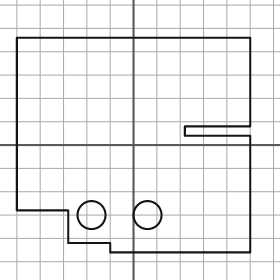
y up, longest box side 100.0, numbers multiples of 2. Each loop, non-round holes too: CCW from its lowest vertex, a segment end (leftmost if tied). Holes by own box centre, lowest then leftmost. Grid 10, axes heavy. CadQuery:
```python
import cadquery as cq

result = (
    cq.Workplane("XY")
    .moveTo(-10.0, -46.0)
    .lineTo(50.0, -46.0)
    .lineTo(50.0, 4.0)
    .lineTo(22.0, 4.0)
    .lineTo(22.0, 8.0)
    .lineTo(50.0, 8.0)
    .lineTo(50.0, 46.0)
    .lineTo(-50.0, 46.0)
    .lineTo(-50.0, -28.0)
    .lineTo(-28.0, -28.0)
    .lineTo(-28.0, -42.0)
    .lineTo(-10.0, -42.0)
    .close()
    .moveTo(-18.0, -30.0)
    .circle(6.0)
    .moveTo(6.0, -30.0)
    .circle(6.0)
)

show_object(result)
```